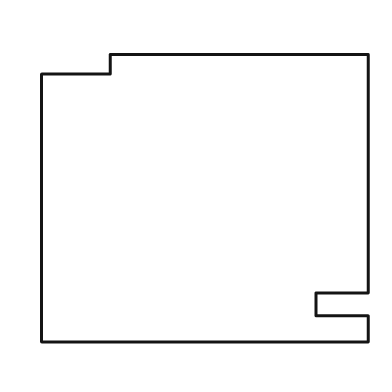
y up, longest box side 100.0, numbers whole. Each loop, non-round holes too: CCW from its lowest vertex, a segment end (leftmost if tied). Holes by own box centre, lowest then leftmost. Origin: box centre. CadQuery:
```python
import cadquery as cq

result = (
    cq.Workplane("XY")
    .moveTo(-50.0, -44.0)
    .lineTo(50.0, -44.0)
    .lineTo(50.0, -36.0)
    .lineTo(34.0, -36.0)
    .lineTo(34.0, -29.0)
    .lineTo(50.0, -29.0)
    .lineTo(50.0, 44.0)
    .lineTo(-29.0, 44.0)
    .lineTo(-29.0, 38.0)
    .lineTo(-50.0, 38.0)
    .close()
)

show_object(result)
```